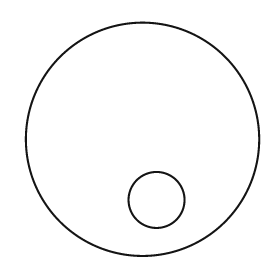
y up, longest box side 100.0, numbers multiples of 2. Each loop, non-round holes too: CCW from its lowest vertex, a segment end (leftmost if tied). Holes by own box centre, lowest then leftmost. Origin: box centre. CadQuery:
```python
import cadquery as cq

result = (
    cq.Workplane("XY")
    .moveTo(0.0, 0.0)
    .circle(50.0)
    .moveTo(6.0, -26.0)
    .circle(12.0)
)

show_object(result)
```